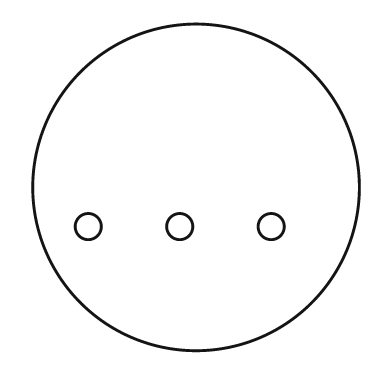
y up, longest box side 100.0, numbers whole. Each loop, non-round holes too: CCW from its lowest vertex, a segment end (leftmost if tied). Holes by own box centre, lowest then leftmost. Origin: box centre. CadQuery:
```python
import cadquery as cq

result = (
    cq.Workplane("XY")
    .moveTo(0.0, 0.0)
    .circle(50.0)
    .moveTo(-33.0, -12.0)
    .circle(4.0)
    .moveTo(-5.0, -12.0)
    .circle(4.0)
    .moveTo(23.0, -12.0)
    .circle(4.0)
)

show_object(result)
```